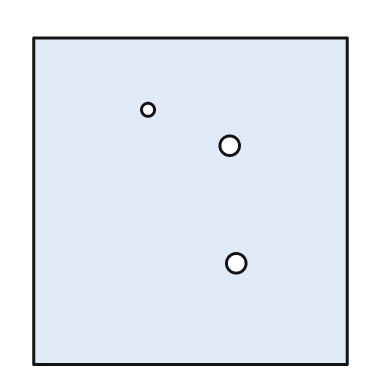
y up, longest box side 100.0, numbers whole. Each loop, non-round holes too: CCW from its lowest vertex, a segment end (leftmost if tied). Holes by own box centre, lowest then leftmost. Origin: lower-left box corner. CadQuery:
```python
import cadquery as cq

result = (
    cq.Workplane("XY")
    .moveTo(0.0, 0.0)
    .lineTo(96.0, 0.0)
    .lineTo(96.0, 100.0)
    .lineTo(0.0, 100.0)
    .close()
    .moveTo(62.0, 31.0)
    .circle(3.0)
    .moveTo(60.0, 67.0)
    .circle(3.0)
    .moveTo(35.0, 78.0)
    .circle(2.0)
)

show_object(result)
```